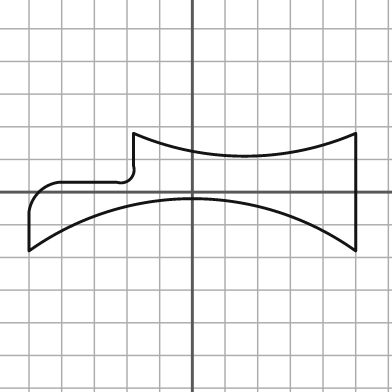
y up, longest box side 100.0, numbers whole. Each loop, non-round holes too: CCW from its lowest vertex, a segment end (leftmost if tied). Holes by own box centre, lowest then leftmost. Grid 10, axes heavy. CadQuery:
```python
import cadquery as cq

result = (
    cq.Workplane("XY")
    .moveTo(-50.0, -18.0)
    .threePointArc((0.0, -2.0), (50.0, -18.0))
    .lineTo(50.0, 18.0)
    .threePointArc((16.0, 11.0), (-18.0, 18.0))
    .lineTo(-18.0, 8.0)
    .threePointArc((-19.0, 4.0), (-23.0, 3.0))
    .lineTo(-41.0, 3.0)
    .threePointArc((-47.0, 0.0), (-50.0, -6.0))
    .close()
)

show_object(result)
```